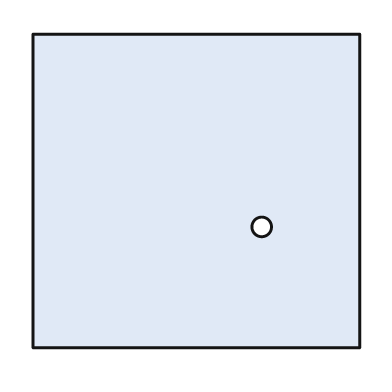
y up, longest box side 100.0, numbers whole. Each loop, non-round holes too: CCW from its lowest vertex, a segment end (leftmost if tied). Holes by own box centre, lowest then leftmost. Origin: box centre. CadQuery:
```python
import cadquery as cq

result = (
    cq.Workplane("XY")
    .moveTo(-50.0, -48.0)
    .lineTo(50.0, -48.0)
    .lineTo(50.0, 48.0)
    .lineTo(-50.0, 48.0)
    .close()
    .moveTo(20.0, -11.0)
    .circle(3.0)
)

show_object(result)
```